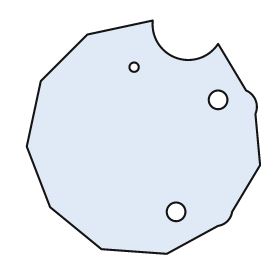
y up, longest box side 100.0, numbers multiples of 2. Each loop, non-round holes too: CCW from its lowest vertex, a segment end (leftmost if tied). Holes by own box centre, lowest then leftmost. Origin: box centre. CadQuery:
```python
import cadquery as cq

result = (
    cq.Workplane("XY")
    .moveTo(10.0, -50.0)
    .lineTo(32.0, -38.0)
    .threePointArc((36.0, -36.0), (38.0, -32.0))
    .lineTo(50.0, -12.0)
    .lineTo(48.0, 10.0)
    .threePointArc((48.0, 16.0), (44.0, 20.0))
    .lineTo(32.0, 40.0)
    .threePointArc((14.0, 34.0), (4.0, 50.0))
    .lineTo(-24.0, 44.0)
    .lineTo(-44.0, 24.0)
    .lineTo(-50.0, -4.0)
    .lineTo(-40.0, -30.0)
    .lineTo(-18.0, -48.0)
    .close()
    .moveTo(14.0, -32.0)
    .circle(4.0)
    .moveTo(32.0, 16.0)
    .circle(4.0)
    .moveTo(-4.0, 30.0)
    .circle(2.0)
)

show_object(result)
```